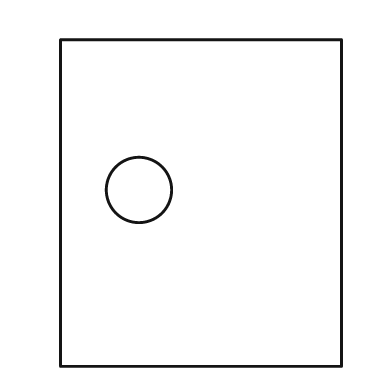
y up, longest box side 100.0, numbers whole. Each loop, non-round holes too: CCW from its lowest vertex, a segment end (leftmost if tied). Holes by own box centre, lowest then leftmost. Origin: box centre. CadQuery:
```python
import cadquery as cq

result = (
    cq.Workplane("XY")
    .moveTo(-43.0, -50.0)
    .lineTo(43.0, -50.0)
    .lineTo(43.0, 50.0)
    .lineTo(-43.0, 50.0)
    .close()
    .moveTo(-19.0, 4.0)
    .circle(10.0)
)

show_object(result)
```